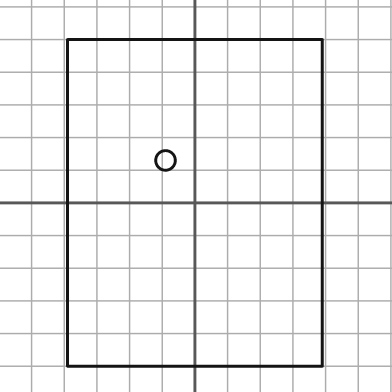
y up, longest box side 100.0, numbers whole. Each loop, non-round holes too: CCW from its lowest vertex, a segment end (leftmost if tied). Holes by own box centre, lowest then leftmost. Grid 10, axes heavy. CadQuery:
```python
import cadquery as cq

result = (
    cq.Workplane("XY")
    .moveTo(-39.0, -50.0)
    .lineTo(39.0, -50.0)
    .lineTo(39.0, 50.0)
    .lineTo(-39.0, 50.0)
    .close()
    .moveTo(-9.0, 13.0)
    .circle(3.0)
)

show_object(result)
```